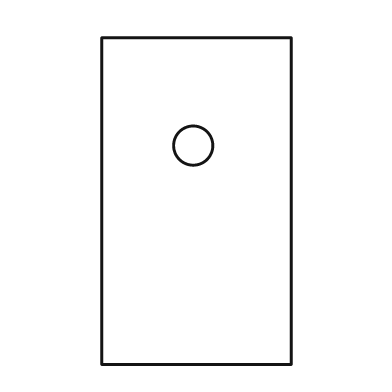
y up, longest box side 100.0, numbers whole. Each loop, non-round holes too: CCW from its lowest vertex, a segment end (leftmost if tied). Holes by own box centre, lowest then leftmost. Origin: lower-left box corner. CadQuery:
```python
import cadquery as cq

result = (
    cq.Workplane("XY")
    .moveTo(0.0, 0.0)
    .lineTo(58.0, 0.0)
    .lineTo(58.0, 100.0)
    .lineTo(0.0, 100.0)
    .close()
    .moveTo(28.0, 67.0)
    .circle(6.0)
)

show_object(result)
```